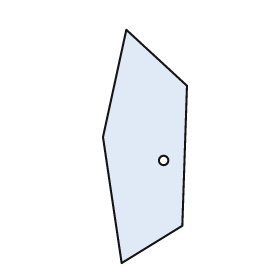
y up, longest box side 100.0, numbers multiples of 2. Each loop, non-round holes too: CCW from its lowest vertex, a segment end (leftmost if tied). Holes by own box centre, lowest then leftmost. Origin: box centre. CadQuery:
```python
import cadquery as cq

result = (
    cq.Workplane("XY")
    .moveTo(-10.0, -50.0)
    .lineTo(16.0, -34.0)
    .lineTo(18.0, 26.0)
    .lineTo(-8.0, 50.0)
    .lineTo(-18.0, 4.0)
    .close()
    .moveTo(8.0, -6.0)
    .circle(2.0)
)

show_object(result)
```